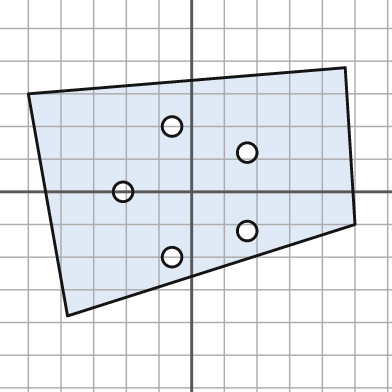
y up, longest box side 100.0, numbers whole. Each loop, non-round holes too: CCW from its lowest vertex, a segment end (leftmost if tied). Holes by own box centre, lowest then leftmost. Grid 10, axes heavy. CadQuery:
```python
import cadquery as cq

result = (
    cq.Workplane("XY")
    .moveTo(-38.0, -38.0)
    .lineTo(50.0, -10.0)
    .lineTo(47.0, 38.0)
    .lineTo(-50.0, 30.0)
    .close()
    .moveTo(-6.0, -20.0)
    .circle(3.0)
    .moveTo(17.0, -12.0)
    .circle(3.0)
    .moveTo(-21.0, 0.0)
    .circle(3.0)
    .moveTo(17.0, 12.0)
    .circle(3.0)
    .moveTo(-6.0, 20.0)
    .circle(3.0)
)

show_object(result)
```